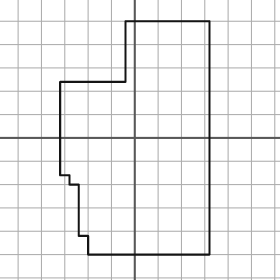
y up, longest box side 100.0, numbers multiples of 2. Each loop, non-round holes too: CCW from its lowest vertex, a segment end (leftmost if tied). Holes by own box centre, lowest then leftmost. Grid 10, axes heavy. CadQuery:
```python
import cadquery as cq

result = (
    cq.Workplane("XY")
    .moveTo(-20.0, -50.0)
    .lineTo(32.0, -50.0)
    .lineTo(32.0, 50.0)
    .lineTo(-4.0, 50.0)
    .lineTo(-4.0, 24.0)
    .lineTo(-32.0, 24.0)
    .lineTo(-32.0, -16.0)
    .lineTo(-28.0, -16.0)
    .lineTo(-28.0, -20.0)
    .lineTo(-24.0, -20.0)
    .lineTo(-24.0, -42.0)
    .lineTo(-20.0, -42.0)
    .close()
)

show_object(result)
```